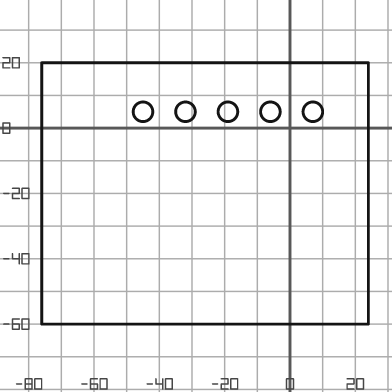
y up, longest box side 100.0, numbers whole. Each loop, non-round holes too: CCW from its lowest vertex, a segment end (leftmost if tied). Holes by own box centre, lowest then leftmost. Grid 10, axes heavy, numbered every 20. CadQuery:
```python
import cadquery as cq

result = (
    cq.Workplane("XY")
    .moveTo(-76.0, -60.0)
    .lineTo(24.0, -60.0)
    .lineTo(24.0, 20.0)
    .lineTo(-76.0, 20.0)
    .close()
    .moveTo(-45.0, 5.0)
    .circle(3.0)
    .moveTo(-32.0, 5.0)
    .circle(3.0)
    .moveTo(-19.0, 5.0)
    .circle(3.0)
    .moveTo(-6.0, 5.0)
    .circle(3.0)
    .moveTo(7.0, 5.0)
    .circle(3.0)
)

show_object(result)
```